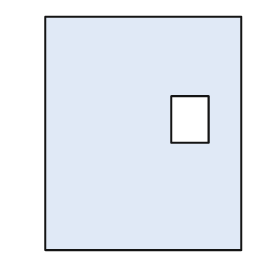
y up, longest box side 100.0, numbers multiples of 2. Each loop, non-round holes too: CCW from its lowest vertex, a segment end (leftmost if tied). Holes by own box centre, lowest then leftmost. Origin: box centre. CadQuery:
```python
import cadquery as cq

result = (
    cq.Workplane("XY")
    .moveTo(-42.0, -50.0)
    .lineTo(42.0, -50.0)
    .lineTo(42.0, 50.0)
    .lineTo(-42.0, 50.0)
    .close()
    .moveTo(12.0, -4.0)
    .lineTo(28.0, -4.0)
    .lineTo(28.0, 16.0)
    .lineTo(12.0, 16.0)
    .close()
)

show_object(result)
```